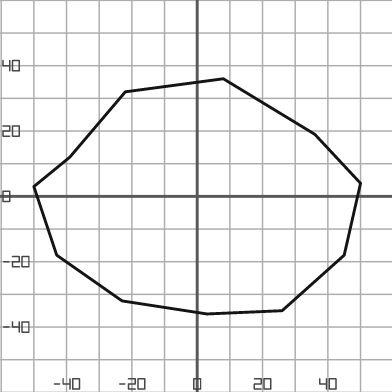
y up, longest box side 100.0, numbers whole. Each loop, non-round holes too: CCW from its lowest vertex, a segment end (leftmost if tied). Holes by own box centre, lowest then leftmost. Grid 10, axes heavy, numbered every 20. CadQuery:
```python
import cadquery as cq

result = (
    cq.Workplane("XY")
    .moveTo(3.0, -36.0)
    .lineTo(26.0, -35.0)
    .lineTo(45.0, -18.0)
    .lineTo(50.0, 4.0)
    .lineTo(36.0, 19.0)
    .lineTo(8.0, 36.0)
    .lineTo(-22.0, 32.0)
    .lineTo(-39.0, 12.0)
    .lineTo(-50.0, 3.0)
    .lineTo(-43.0, -18.0)
    .lineTo(-23.0, -32.0)
    .close()
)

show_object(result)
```